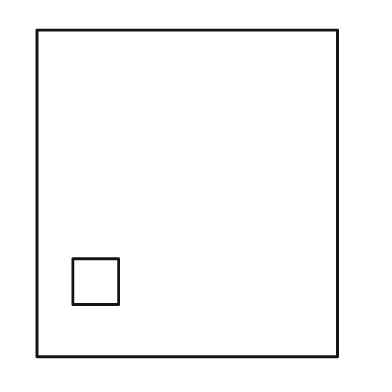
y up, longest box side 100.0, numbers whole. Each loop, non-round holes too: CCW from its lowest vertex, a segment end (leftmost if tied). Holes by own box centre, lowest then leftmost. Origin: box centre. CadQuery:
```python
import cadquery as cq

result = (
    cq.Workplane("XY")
    .moveTo(-46.0, -50.0)
    .lineTo(46.0, -50.0)
    .lineTo(46.0, 50.0)
    .lineTo(-46.0, 50.0)
    .close()
    .moveTo(-35.0, -34.0)
    .lineTo(-21.0, -34.0)
    .lineTo(-21.0, -20.0)
    .lineTo(-35.0, -20.0)
    .close()
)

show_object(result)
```